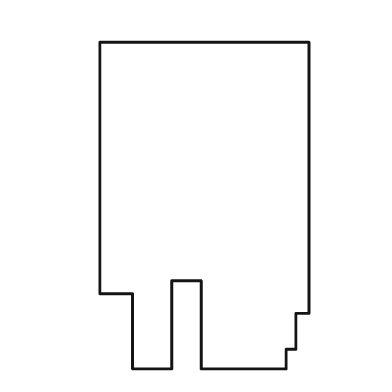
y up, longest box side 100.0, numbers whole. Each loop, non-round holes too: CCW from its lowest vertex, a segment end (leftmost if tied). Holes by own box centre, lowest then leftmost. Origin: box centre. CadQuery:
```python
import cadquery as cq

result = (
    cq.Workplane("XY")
    .moveTo(-22.0, -50.0)
    .lineTo(-10.0, -50.0)
    .lineTo(-10.0, -23.0)
    .lineTo(-1.0, -23.0)
    .lineTo(-1.0, -50.0)
    .lineTo(25.0, -50.0)
    .lineTo(25.0, -44.0)
    .lineTo(28.0, -44.0)
    .lineTo(28.0, -33.0)
    .lineTo(32.0, -33.0)
    .lineTo(32.0, 50.0)
    .lineTo(-32.0, 50.0)
    .lineTo(-32.0, -27.0)
    .lineTo(-22.0, -27.0)
    .close()
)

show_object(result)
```